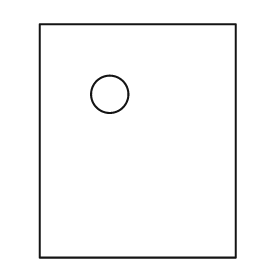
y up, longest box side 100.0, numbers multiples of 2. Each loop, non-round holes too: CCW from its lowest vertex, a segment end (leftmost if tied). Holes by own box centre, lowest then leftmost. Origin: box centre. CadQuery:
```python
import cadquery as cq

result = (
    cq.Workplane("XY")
    .moveTo(-42.0, -50.0)
    .lineTo(42.0, -50.0)
    .lineTo(42.0, 50.0)
    .lineTo(-42.0, 50.0)
    .close()
    .moveTo(-12.0, 20.0)
    .circle(8.0)
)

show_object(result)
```